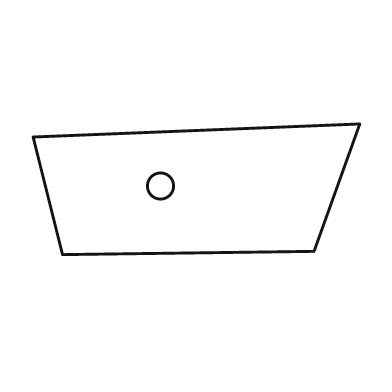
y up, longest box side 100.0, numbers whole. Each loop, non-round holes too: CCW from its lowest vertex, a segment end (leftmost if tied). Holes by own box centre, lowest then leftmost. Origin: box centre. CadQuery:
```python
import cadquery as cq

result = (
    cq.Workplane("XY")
    .moveTo(-41.0, -20.0)
    .lineTo(36.0, -19.0)
    .lineTo(50.0, 20.0)
    .lineTo(-50.0, 16.0)
    .close()
    .moveTo(-11.0, 1.0)
    .circle(4.0)
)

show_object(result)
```